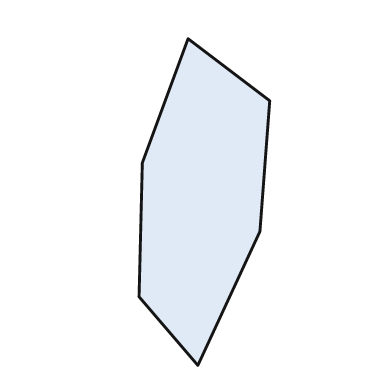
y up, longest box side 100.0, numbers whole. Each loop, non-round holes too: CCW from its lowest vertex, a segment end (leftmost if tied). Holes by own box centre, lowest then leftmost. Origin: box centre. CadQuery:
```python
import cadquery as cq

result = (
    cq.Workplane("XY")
    .moveTo(-2.0, -50.0)
    .lineTo(17.0, -9.0)
    .lineTo(20.0, 31.0)
    .lineTo(-5.0, 50.0)
    .lineTo(-19.0, 12.0)
    .lineTo(-20.0, -29.0)
    .close()
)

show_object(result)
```